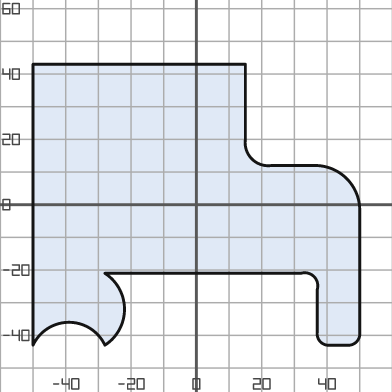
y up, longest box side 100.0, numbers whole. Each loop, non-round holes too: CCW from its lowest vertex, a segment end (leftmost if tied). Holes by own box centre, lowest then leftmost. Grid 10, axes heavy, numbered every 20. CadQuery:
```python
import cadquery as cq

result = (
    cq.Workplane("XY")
    .moveTo(-50.0, -43.0)
    .threePointArc((-39.0, -36.0), (-28.0, -43.0))
    .threePointArc((-22.0, -32.0), (-28.0, -21.0))
    .lineTo(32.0, -21.0)
    .threePointArc((36.0, -22.0), (37.0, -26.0))
    .lineTo(37.0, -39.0)
    .threePointArc((38.0, -42.0), (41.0, -43.0))
    .lineTo(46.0, -43.0)
    .threePointArc((49.0, -42.0), (50.0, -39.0))
    .lineTo(50.0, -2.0)
    .threePointArc((46.0, 8.0), (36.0, 12.0))
    .lineTo(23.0, 12.0)
    .threePointArc((17.0, 14.0), (15.0, 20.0))
    .lineTo(15.0, 43.0)
    .lineTo(-50.0, 43.0)
    .close()
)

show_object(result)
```